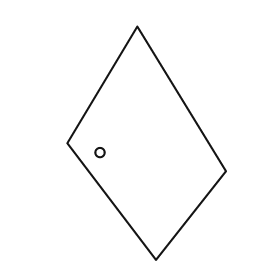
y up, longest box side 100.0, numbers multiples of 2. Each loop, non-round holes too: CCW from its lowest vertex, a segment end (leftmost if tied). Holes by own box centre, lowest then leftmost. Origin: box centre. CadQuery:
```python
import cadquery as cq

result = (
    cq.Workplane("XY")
    .moveTo(4.0, -50.0)
    .lineTo(34.0, -12.0)
    .lineTo(-4.0, 50.0)
    .lineTo(-34.0, 0.0)
    .close()
    .moveTo(-20.0, -4.0)
    .circle(2.0)
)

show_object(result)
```